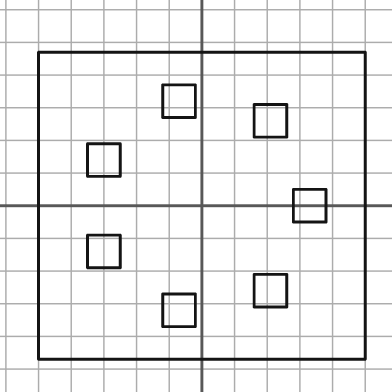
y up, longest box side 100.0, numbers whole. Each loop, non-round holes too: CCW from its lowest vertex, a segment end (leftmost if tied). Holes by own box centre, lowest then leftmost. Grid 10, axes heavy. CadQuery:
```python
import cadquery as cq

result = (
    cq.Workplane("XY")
    .moveTo(-50.0, -47.0)
    .lineTo(50.0, -47.0)
    .lineTo(50.0, 47.0)
    .lineTo(-50.0, 47.0)
    .close()
    .moveTo(-12.0, -37.0)
    .lineTo(-2.0, -37.0)
    .lineTo(-2.0, -27.0)
    .lineTo(-12.0, -27.0)
    .close()
    .moveTo(16.0, -31.0)
    .lineTo(26.0, -31.0)
    .lineTo(26.0, -21.0)
    .lineTo(16.0, -21.0)
    .close()
    .moveTo(-35.0, -19.0)
    .lineTo(-25.0, -19.0)
    .lineTo(-25.0, -9.0)
    .lineTo(-35.0, -9.0)
    .close()
    .moveTo(28.0, -5.0)
    .lineTo(38.0, -5.0)
    .lineTo(38.0, 5.0)
    .lineTo(28.0, 5.0)
    .close()
    .moveTo(-35.0, 9.0)
    .lineTo(-25.0, 9.0)
    .lineTo(-25.0, 19.0)
    .lineTo(-35.0, 19.0)
    .close()
    .moveTo(16.0, 21.0)
    .lineTo(26.0, 21.0)
    .lineTo(26.0, 31.0)
    .lineTo(16.0, 31.0)
    .close()
    .moveTo(-12.0, 27.0)
    .lineTo(-2.0, 27.0)
    .lineTo(-2.0, 37.0)
    .lineTo(-12.0, 37.0)
    .close()
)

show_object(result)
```